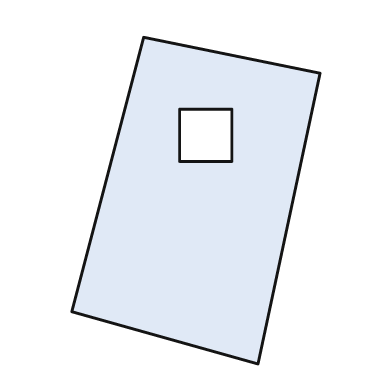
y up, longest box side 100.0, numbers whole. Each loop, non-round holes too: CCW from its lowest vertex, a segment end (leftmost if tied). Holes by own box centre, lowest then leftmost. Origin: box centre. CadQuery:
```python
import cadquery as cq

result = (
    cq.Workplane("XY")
    .moveTo(19.0, -50.0)
    .lineTo(38.0, 39.0)
    .lineTo(-16.0, 50.0)
    .lineTo(-38.0, -34.0)
    .close()
    .moveTo(-5.0, 12.0)
    .lineTo(11.0, 12.0)
    .lineTo(11.0, 28.0)
    .lineTo(-5.0, 28.0)
    .close()
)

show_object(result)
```